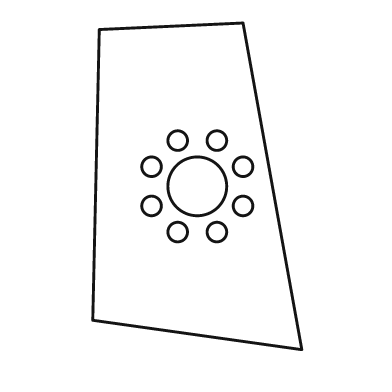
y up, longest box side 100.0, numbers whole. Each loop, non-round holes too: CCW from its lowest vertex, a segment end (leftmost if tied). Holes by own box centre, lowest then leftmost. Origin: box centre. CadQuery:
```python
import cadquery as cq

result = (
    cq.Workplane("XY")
    .moveTo(32.0, -50.0)
    .lineTo(14.0, 50.0)
    .lineTo(-30.0, 48.0)
    .lineTo(-32.0, -41.0)
    .close()
    .moveTo(-6.0, -14.0)
    .circle(3.0)
    .moveTo(6.0, -14.0)
    .circle(3.0)
    .moveTo(-14.0, -6.0)
    .circle(3.0)
    .moveTo(14.0, -6.0)
    .circle(3.0)
    .moveTo(0.0, 0.0)
    .circle(9.0)
    .moveTo(-14.0, 6.0)
    .circle(3.0)
    .moveTo(14.0, 6.0)
    .circle(3.0)
    .moveTo(-6.0, 14.0)
    .circle(3.0)
    .moveTo(6.0, 14.0)
    .circle(3.0)
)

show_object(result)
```